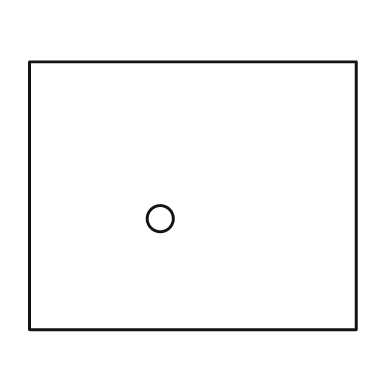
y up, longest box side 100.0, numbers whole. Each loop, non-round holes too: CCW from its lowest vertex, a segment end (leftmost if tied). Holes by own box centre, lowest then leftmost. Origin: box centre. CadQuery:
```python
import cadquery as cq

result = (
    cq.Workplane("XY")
    .moveTo(-50.0, -41.0)
    .lineTo(50.0, -41.0)
    .lineTo(50.0, 41.0)
    .lineTo(-50.0, 41.0)
    .close()
    .moveTo(-10.0, -7.0)
    .circle(4.0)
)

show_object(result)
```